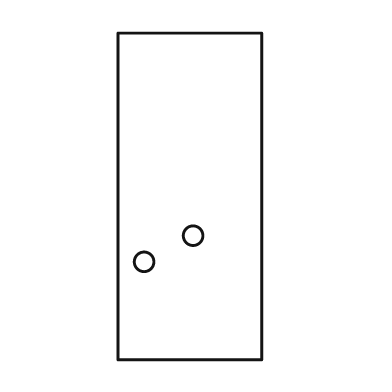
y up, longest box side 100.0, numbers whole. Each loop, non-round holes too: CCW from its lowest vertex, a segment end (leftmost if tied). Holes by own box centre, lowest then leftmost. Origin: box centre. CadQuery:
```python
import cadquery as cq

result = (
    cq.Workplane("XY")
    .moveTo(-22.0, -50.0)
    .lineTo(22.0, -50.0)
    .lineTo(22.0, 50.0)
    .lineTo(-22.0, 50.0)
    .close()
    .moveTo(-14.0, -20.0)
    .circle(3.0)
    .moveTo(1.0, -12.0)
    .circle(3.0)
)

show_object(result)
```